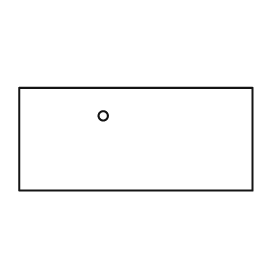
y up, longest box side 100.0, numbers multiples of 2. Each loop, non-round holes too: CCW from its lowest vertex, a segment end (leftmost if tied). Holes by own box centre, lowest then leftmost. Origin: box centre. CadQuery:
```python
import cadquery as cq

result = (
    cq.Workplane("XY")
    .moveTo(-50.0, -22.0)
    .lineTo(50.0, -22.0)
    .lineTo(50.0, 22.0)
    .lineTo(-50.0, 22.0)
    .close()
    .moveTo(-14.0, 10.0)
    .circle(2.0)
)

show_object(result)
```